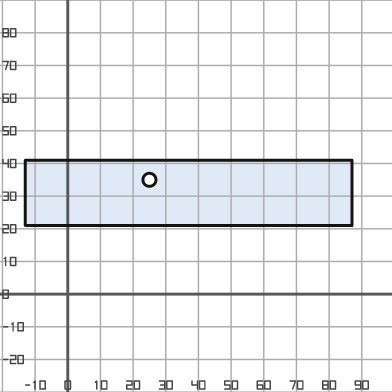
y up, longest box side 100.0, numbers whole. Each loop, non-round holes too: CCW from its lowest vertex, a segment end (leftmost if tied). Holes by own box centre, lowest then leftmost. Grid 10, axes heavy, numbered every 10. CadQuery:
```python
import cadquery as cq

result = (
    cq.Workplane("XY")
    .moveTo(-13.0, 21.0)
    .lineTo(87.0, 21.0)
    .lineTo(87.0, 41.0)
    .lineTo(-13.0, 41.0)
    .close()
    .moveTo(25.0, 35.0)
    .circle(2.0)
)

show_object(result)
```